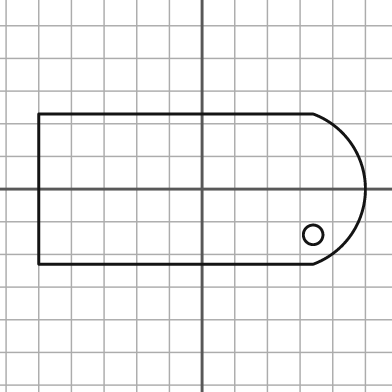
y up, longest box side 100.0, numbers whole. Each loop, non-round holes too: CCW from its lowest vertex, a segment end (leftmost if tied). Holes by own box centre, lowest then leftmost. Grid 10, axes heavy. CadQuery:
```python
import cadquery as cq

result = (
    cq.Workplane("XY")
    .moveTo(-50.0, -23.0)
    .lineTo(34.0, -23.0)
    .threePointArc((50.0, 0.0), (34.0, 23.0))
    .lineTo(-50.0, 23.0)
    .close()
    .moveTo(34.0, -14.0)
    .circle(3.0)
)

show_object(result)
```